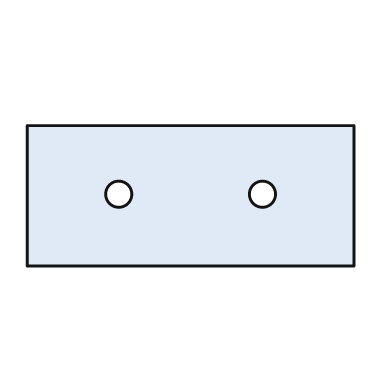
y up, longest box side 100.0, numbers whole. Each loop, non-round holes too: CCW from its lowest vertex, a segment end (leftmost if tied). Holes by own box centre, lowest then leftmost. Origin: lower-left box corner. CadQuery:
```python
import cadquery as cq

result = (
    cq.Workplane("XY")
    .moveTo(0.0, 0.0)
    .lineTo(100.0, 0.0)
    .lineTo(100.0, 43.0)
    .lineTo(0.0, 43.0)
    .close()
    .moveTo(28.0, 22.0)
    .circle(4.0)
    .moveTo(72.0, 22.0)
    .circle(4.0)
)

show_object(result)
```